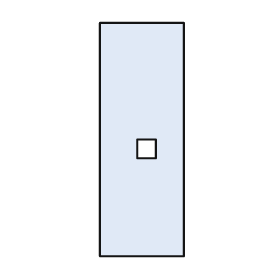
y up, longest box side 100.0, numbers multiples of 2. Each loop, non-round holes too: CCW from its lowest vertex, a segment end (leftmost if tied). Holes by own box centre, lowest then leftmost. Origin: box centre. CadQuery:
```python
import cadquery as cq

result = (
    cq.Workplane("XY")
    .moveTo(-18.0, -50.0)
    .lineTo(18.0, -50.0)
    .lineTo(18.0, 50.0)
    .lineTo(-18.0, 50.0)
    .close()
    .moveTo(-2.0, -8.0)
    .lineTo(6.0, -8.0)
    .lineTo(6.0, 0.0)
    .lineTo(-2.0, 0.0)
    .close()
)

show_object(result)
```